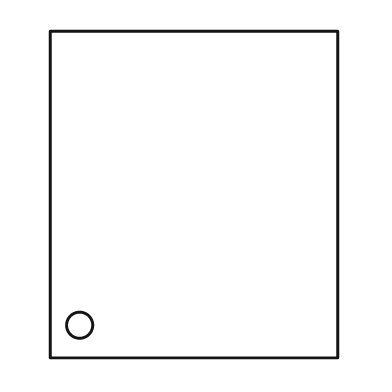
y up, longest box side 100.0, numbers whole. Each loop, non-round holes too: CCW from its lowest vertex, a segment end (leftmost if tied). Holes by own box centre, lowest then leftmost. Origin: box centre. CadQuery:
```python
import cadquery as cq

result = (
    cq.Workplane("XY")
    .moveTo(-44.0, -50.0)
    .lineTo(44.0, -50.0)
    .lineTo(44.0, 50.0)
    .lineTo(-44.0, 50.0)
    .close()
    .moveTo(-35.0, -40.0)
    .circle(4.0)
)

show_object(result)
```